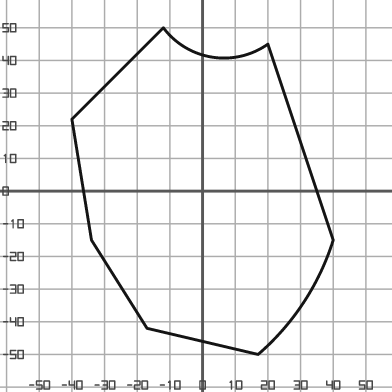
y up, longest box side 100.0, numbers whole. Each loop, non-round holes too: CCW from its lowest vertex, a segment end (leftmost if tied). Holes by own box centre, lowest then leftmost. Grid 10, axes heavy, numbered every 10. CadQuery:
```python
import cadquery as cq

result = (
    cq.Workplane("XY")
    .moveTo(17.0, -50.0)
    .threePointArc((31.0, -34.0), (40.0, -15.0))
    .lineTo(20.0, 45.0)
    .threePointArc((3.0, 41.0), (-12.0, 50.0))
    .lineTo(-40.0, 22.0)
    .lineTo(-34.0, -15.0)
    .lineTo(-17.0, -42.0)
    .close()
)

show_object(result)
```